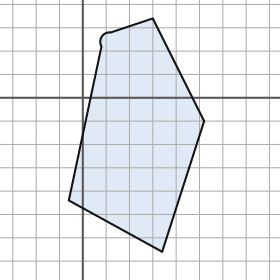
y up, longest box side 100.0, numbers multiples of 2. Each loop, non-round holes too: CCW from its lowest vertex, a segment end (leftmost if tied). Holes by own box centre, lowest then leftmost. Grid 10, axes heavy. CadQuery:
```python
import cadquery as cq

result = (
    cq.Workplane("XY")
    .moveTo(34.0, -66.0)
    .lineTo(52.0, -10.0)
    .lineTo(30.0, 34.0)
    .lineTo(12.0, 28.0)
    .threePointArc((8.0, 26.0), (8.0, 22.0))
    .lineTo(-6.0, -44.0)
    .close()
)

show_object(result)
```